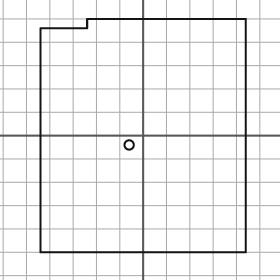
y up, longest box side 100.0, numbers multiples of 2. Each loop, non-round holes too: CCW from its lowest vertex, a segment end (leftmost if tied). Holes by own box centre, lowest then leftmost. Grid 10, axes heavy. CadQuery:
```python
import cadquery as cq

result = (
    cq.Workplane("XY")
    .moveTo(-44.0, -50.0)
    .lineTo(44.0, -50.0)
    .lineTo(44.0, 50.0)
    .lineTo(-24.0, 50.0)
    .lineTo(-24.0, 46.0)
    .lineTo(-44.0, 46.0)
    .close()
    .moveTo(-6.0, -4.0)
    .circle(2.0)
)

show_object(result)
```